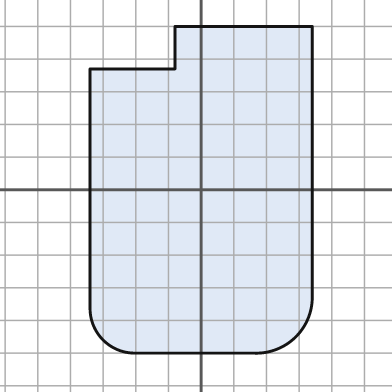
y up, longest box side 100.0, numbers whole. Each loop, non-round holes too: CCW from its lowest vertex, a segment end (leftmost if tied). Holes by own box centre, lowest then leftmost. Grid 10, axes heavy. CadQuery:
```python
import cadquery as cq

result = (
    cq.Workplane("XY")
    .moveTo(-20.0, -50.0)
    .lineTo(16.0, -50.0)
    .threePointArc((29.0, -45.0), (34.0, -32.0))
    .lineTo(34.0, 50.0)
    .lineTo(-8.0, 50.0)
    .lineTo(-8.0, 37.0)
    .lineTo(-34.0, 37.0)
    .lineTo(-34.0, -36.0)
    .threePointArc((-30.0, -46.0), (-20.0, -50.0))
    .close()
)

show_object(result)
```